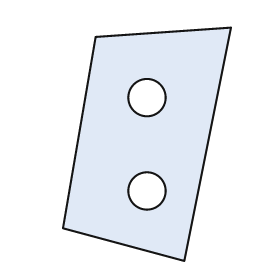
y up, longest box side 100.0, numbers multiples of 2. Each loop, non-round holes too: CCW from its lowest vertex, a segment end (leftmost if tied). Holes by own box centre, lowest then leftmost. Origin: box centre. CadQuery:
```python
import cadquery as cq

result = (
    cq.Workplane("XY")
    .moveTo(16.0, -50.0)
    .lineTo(36.0, 50.0)
    .lineTo(-22.0, 46.0)
    .lineTo(-36.0, -36.0)
    .close()
    .moveTo(0.0, -20.0)
    .circle(8.0)
    .moveTo(0.0, 20.0)
    .circle(8.0)
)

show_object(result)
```